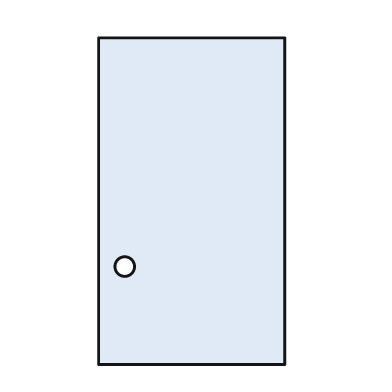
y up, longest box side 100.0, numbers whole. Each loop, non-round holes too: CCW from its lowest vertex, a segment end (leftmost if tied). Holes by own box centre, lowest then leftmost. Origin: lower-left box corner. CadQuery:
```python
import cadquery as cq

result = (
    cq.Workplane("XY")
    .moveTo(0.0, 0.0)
    .lineTo(57.0, 0.0)
    .lineTo(57.0, 100.0)
    .lineTo(0.0, 100.0)
    .close()
    .moveTo(8.0, 30.0)
    .circle(3.0)
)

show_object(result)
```